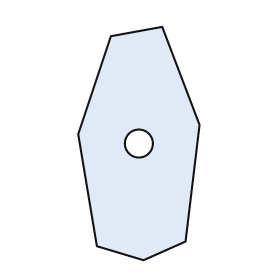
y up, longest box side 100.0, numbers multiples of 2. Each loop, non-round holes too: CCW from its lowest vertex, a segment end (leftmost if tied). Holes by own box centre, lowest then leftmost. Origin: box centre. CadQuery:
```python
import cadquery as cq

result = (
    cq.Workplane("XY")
    .moveTo(2.0, -50.0)
    .lineTo(20.0, -42.0)
    .lineTo(26.0, 8.0)
    .lineTo(10.0, 50.0)
    .lineTo(-12.0, 46.0)
    .lineTo(-26.0, 4.0)
    .lineTo(-18.0, -44.0)
    .close()
    .moveTo(0.0, 0.0)
    .circle(6.0)
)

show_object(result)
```